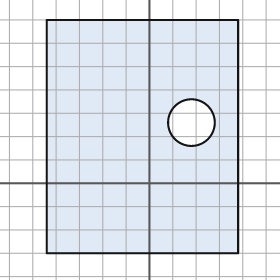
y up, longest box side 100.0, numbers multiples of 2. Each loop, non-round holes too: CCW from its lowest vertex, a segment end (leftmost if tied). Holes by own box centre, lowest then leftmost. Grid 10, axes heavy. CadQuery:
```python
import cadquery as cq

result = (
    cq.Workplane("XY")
    .moveTo(-44.0, -30.0)
    .lineTo(38.0, -30.0)
    .lineTo(38.0, 70.0)
    .lineTo(-44.0, 70.0)
    .close()
    .moveTo(18.0, 26.0)
    .circle(10.0)
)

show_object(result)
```